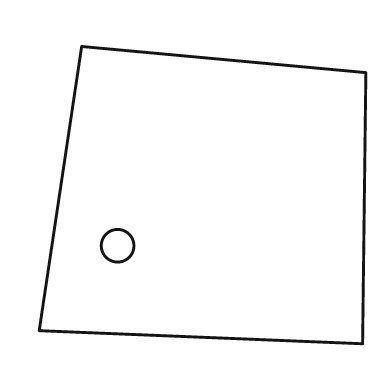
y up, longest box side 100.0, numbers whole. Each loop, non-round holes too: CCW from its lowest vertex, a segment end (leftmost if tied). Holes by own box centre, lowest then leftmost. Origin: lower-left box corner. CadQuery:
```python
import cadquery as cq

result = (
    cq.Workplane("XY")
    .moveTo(99.0, 0.0)
    .lineTo(100.0, 83.0)
    .lineTo(13.0, 91.0)
    .lineTo(0.0, 4.0)
    .close()
    .moveTo(24.0, 30.0)
    .circle(5.0)
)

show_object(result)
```